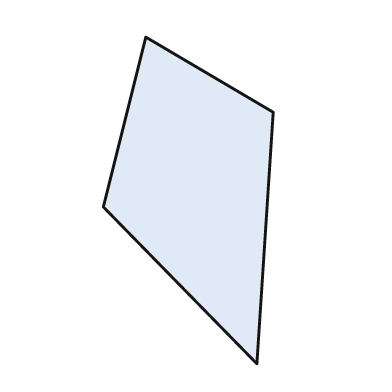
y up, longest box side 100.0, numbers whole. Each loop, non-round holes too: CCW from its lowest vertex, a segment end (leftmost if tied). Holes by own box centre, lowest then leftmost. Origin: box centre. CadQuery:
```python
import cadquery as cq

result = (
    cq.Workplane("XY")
    .moveTo(21.0, -50.0)
    .lineTo(26.0, 27.0)
    .lineTo(-13.0, 50.0)
    .lineTo(-26.0, -2.0)
    .close()
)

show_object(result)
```